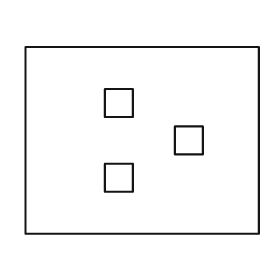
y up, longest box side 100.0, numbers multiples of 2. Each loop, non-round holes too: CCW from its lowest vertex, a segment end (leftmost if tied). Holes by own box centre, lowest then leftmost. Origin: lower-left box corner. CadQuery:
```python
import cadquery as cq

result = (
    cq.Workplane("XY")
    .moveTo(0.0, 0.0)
    .lineTo(100.0, 0.0)
    .lineTo(100.0, 80.0)
    .lineTo(0.0, 80.0)
    .close()
    .moveTo(34.0, 18.0)
    .lineTo(46.0, 18.0)
    .lineTo(46.0, 30.0)
    .lineTo(34.0, 30.0)
    .close()
    .moveTo(64.0, 34.0)
    .lineTo(76.0, 34.0)
    .lineTo(76.0, 46.0)
    .lineTo(64.0, 46.0)
    .close()
    .moveTo(34.0, 50.0)
    .lineTo(46.0, 50.0)
    .lineTo(46.0, 62.0)
    .lineTo(34.0, 62.0)
    .close()
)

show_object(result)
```